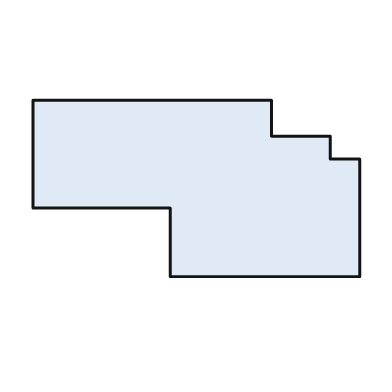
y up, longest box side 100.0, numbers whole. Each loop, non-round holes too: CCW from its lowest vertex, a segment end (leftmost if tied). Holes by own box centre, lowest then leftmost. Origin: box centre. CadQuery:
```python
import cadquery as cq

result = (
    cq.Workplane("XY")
    .moveTo(-8.0, -27.0)
    .lineTo(50.0, -27.0)
    .lineTo(50.0, 9.0)
    .lineTo(41.0, 9.0)
    .lineTo(41.0, 16.0)
    .lineTo(23.0, 16.0)
    .lineTo(23.0, 27.0)
    .lineTo(-50.0, 27.0)
    .lineTo(-50.0, -6.0)
    .lineTo(-8.0, -6.0)
    .close()
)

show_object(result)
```